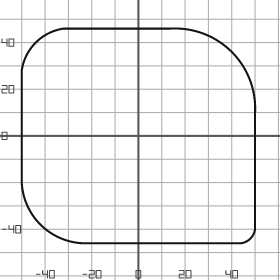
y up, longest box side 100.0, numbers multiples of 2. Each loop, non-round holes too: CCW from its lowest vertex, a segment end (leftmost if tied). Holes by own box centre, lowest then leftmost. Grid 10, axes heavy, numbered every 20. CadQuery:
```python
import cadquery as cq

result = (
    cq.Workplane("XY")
    .moveTo(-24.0, -46.0)
    .lineTo(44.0, -46.0)
    .threePointArc((48.0, -44.0), (50.0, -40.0))
    .lineTo(50.0, 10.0)
    .threePointArc((40.0, 36.0), (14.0, 46.0))
    .lineTo(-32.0, 46.0)
    .threePointArc((-44.0, 40.0), (-50.0, 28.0))
    .lineTo(-50.0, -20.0)
    .threePointArc((-42.0, -38.0), (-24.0, -46.0))
    .close()
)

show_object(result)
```